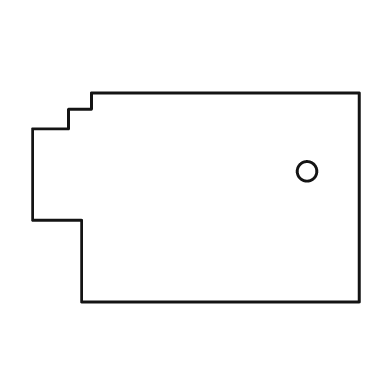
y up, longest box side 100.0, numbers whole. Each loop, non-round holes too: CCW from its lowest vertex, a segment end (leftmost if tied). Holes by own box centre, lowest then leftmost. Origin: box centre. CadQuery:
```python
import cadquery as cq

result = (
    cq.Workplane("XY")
    .moveTo(-35.0, -32.0)
    .lineTo(50.0, -32.0)
    .lineTo(50.0, 32.0)
    .lineTo(-32.0, 32.0)
    .lineTo(-32.0, 27.0)
    .lineTo(-39.0, 27.0)
    .lineTo(-39.0, 21.0)
    .lineTo(-50.0, 21.0)
    .lineTo(-50.0, -7.0)
    .lineTo(-35.0, -7.0)
    .close()
    .moveTo(34.0, 8.0)
    .circle(3.0)
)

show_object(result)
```